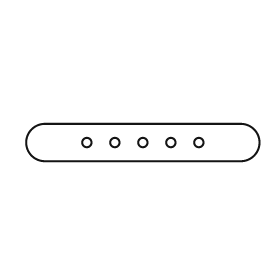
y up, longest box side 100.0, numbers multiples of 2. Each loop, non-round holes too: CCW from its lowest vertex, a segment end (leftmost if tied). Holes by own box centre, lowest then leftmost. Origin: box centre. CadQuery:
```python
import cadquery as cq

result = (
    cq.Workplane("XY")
    .moveTo(-42.0, -8.0)
    .lineTo(42.0, -8.0)
    .threePointArc((50.0, 0.0), (42.0, 8.0))
    .lineTo(-42.0, 8.0)
    .threePointArc((-50.0, 0.0), (-42.0, -8.0))
    .close()
    .moveTo(-24.0, 0.0)
    .circle(2.0)
    .moveTo(-12.0, 0.0)
    .circle(2.0)
    .moveTo(0.0, 0.0)
    .circle(2.0)
    .moveTo(12.0, 0.0)
    .circle(2.0)
    .moveTo(24.0, 0.0)
    .circle(2.0)
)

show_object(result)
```